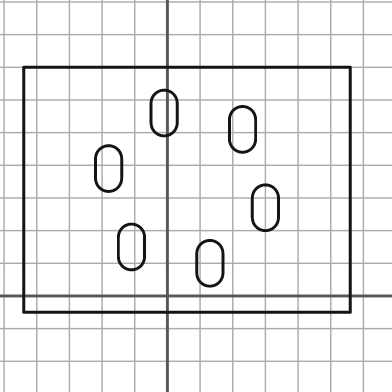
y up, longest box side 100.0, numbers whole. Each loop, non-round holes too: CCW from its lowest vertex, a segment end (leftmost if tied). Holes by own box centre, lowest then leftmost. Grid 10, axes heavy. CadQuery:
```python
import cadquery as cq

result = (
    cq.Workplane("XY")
    .moveTo(-44.0, -5.0)
    .lineTo(56.0, -5.0)
    .lineTo(56.0, 70.0)
    .lineTo(-44.0, 70.0)
    .close()
    .moveTo(9.0, 7.0)
    .threePointArc((13.0, 3.0), (17.0, 7.0))
    .lineTo(17.0, 13.0)
    .threePointArc((13.0, 17.0), (9.0, 13.0))
    .close()
    .moveTo(-15.0, 12.0)
    .threePointArc((-11.0, 8.0), (-7.0, 12.0))
    .lineTo(-7.0, 18.0)
    .threePointArc((-11.0, 22.0), (-15.0, 18.0))
    .close()
    .moveTo(26.0, 24.0)
    .threePointArc((30.0, 20.0), (34.0, 24.0))
    .lineTo(34.0, 30.0)
    .threePointArc((30.0, 34.0), (26.0, 30.0))
    .close()
    .moveTo(-22.0, 36.0)
    .threePointArc((-18.0, 32.0), (-14.0, 36.0))
    .lineTo(-14.0, 42.0)
    .threePointArc((-18.0, 46.0), (-22.0, 42.0))
    .close()
    .moveTo(19.0, 48.0)
    .threePointArc((23.0, 44.0), (27.0, 48.0))
    .lineTo(27.0, 54.0)
    .threePointArc((23.0, 58.0), (19.0, 54.0))
    .close()
    .moveTo(-5.0, 53.0)
    .threePointArc((-1.0, 49.0), (3.0, 53.0))
    .lineTo(3.0, 59.0)
    .threePointArc((-1.0, 63.0), (-5.0, 59.0))
    .close()
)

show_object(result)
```